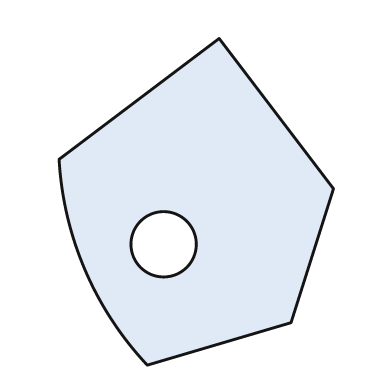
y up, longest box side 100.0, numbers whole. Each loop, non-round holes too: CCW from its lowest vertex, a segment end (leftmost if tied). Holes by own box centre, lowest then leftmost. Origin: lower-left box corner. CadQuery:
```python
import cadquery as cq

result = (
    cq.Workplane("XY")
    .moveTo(27.0, 0.0)
    .lineTo(71.0, 13.0)
    .lineTo(84.0, 54.0)
    .lineTo(49.0, 100.0)
    .lineTo(0.0, 63.0)
    .threePointArc((8.0, 29.0), (27.0, 0.0))
    .close()
    .moveTo(32.0, 37.0)
    .circle(10.0)
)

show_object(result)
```